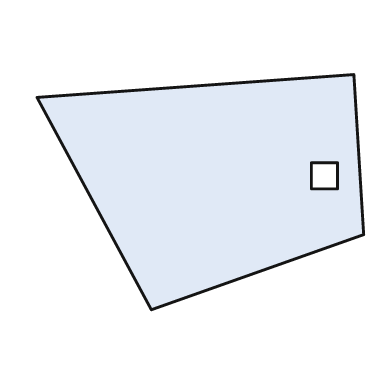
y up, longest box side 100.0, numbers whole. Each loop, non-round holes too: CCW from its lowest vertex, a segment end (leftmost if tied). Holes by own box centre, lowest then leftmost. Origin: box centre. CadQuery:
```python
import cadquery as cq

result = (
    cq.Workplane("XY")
    .moveTo(-15.0, -36.0)
    .lineTo(50.0, -13.0)
    .lineTo(47.0, 36.0)
    .lineTo(-50.0, 29.0)
    .close()
    .moveTo(34.0, 1.0)
    .lineTo(42.0, 1.0)
    .lineTo(42.0, 9.0)
    .lineTo(34.0, 9.0)
    .close()
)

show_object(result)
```